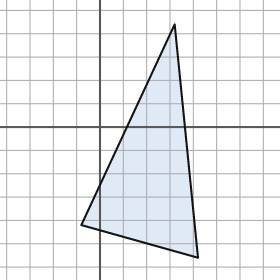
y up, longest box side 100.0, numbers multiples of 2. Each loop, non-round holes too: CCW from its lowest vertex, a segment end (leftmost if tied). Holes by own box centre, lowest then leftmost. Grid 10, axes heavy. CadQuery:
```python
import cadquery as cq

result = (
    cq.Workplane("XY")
    .moveTo(42.0, -56.0)
    .lineTo(32.0, 44.0)
    .lineTo(-8.0, -42.0)
    .close()
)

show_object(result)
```